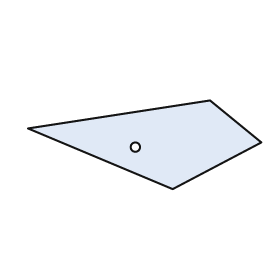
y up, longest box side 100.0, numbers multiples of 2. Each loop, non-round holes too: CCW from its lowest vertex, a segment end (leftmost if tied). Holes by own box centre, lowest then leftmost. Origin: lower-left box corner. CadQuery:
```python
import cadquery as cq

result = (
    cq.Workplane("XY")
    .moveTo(62.0, 0.0)
    .lineTo(100.0, 20.0)
    .lineTo(78.0, 38.0)
    .lineTo(0.0, 26.0)
    .close()
    .moveTo(46.0, 18.0)
    .circle(2.0)
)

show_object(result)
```